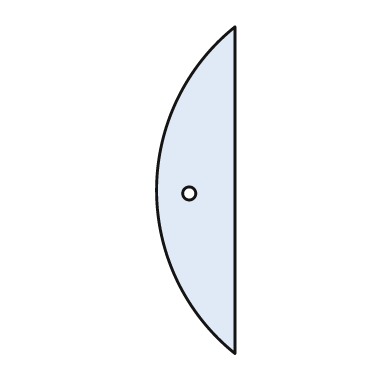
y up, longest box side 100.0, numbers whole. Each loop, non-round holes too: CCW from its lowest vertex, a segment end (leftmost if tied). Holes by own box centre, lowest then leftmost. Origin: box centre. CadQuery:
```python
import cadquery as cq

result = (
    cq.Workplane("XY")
    .moveTo(12.0, -50.0)
    .lineTo(12.0, 50.0)
    .threePointArc((-12.0, 0.0), (12.0, -50.0))
    .close()
    .moveTo(-2.0, -1.0)
    .circle(2.0)
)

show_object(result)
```